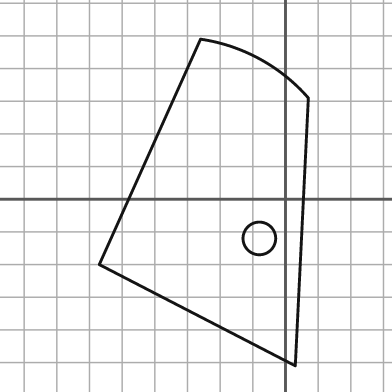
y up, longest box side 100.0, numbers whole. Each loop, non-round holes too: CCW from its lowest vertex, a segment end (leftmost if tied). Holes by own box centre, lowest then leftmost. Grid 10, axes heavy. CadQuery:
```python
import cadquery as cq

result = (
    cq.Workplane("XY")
    .moveTo(3.0, -51.0)
    .lineTo(7.0, 31.0)
    .threePointArc((-8.0, 43.0), (-26.0, 49.0))
    .lineTo(-57.0, -20.0)
    .close()
    .moveTo(-8.0, -12.0)
    .circle(5.0)
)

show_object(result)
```